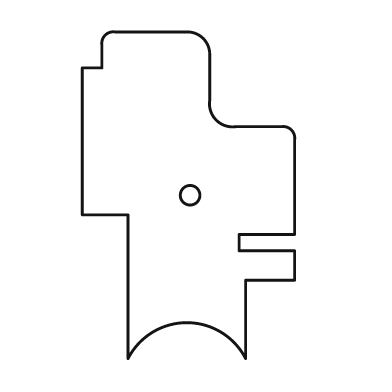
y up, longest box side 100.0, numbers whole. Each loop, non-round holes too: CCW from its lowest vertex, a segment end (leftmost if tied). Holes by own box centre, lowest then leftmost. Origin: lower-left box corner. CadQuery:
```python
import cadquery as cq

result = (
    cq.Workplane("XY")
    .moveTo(14.0, 0.0)
    .threePointArc((32.0, 11.0), (50.0, 0.0))
    .lineTo(50.0, 24.0)
    .lineTo(65.0, 24.0)
    .lineTo(65.0, 33.0)
    .lineTo(48.0, 33.0)
    .lineTo(48.0, 38.0)
    .lineTo(65.0, 38.0)
    .lineTo(65.0, 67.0)
    .threePointArc((64.0, 70.0), (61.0, 71.0))
    .lineTo(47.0, 71.0)
    .threePointArc((41.0, 73.0), (39.0, 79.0))
    .lineTo(39.0, 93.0)
    .threePointArc((37.0, 98.0), (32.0, 100.0))
    .lineTo(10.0, 100.0)
    .threePointArc((7.0, 99.0), (6.0, 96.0))
    .lineTo(6.0, 89.0)
    .lineTo(0.0, 89.0)
    .lineTo(0.0, 44.0)
    .lineTo(14.0, 44.0)
    .close()
    .moveTo(33.0, 50.0)
    .circle(3.0)
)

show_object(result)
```